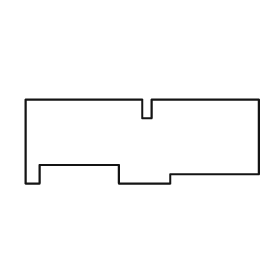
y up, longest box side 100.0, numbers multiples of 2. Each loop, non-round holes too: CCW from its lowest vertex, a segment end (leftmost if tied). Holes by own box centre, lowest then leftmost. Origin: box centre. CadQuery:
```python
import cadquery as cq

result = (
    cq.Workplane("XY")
    .moveTo(-50.0, -18.0)
    .lineTo(-44.0, -18.0)
    .lineTo(-44.0, -10.0)
    .lineTo(-10.0, -10.0)
    .lineTo(-10.0, -18.0)
    .lineTo(12.0, -18.0)
    .lineTo(12.0, -14.0)
    .lineTo(50.0, -14.0)
    .lineTo(50.0, 18.0)
    .lineTo(4.0, 18.0)
    .lineTo(4.0, 10.0)
    .lineTo(0.0, 10.0)
    .lineTo(0.0, 18.0)
    .lineTo(-50.0, 18.0)
    .close()
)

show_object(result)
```